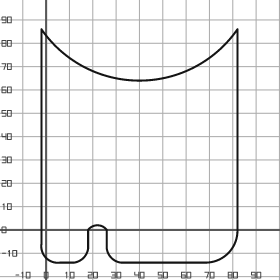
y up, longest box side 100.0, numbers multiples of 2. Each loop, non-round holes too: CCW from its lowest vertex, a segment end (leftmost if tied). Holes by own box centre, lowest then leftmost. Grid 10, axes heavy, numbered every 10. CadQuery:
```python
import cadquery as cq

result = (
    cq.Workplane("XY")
    .moveTo(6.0, -14.0)
    .lineTo(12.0, -14.0)
    .threePointArc((16.0, -12.0), (18.0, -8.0))
    .lineTo(18.0, 0.0)
    .threePointArc((22.0, 2.0), (26.0, 0.0))
    .lineTo(26.0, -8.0)
    .threePointArc((28.0, -12.0), (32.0, -14.0))
    .lineTo(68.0, -14.0)
    .threePointArc((78.0, -10.0), (82.0, 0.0))
    .lineTo(82.0, 86.0)
    .threePointArc((40.0, 64.0), (-2.0, 86.0))
    .lineTo(-2.0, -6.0)
    .threePointArc((0.0, -12.0), (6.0, -14.0))
    .close()
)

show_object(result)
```